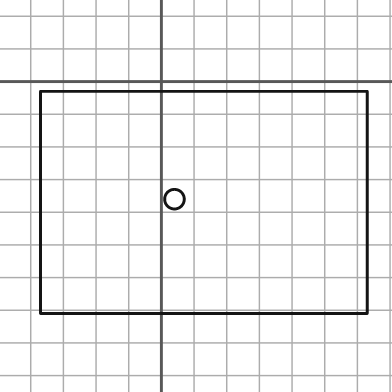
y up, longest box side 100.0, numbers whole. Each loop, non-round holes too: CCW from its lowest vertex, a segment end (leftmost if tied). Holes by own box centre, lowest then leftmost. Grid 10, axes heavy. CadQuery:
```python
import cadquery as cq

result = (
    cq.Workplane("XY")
    .moveTo(-37.0, -71.0)
    .lineTo(63.0, -71.0)
    .lineTo(63.0, -3.0)
    .lineTo(-37.0, -3.0)
    .close()
    .moveTo(4.0, -36.0)
    .circle(3.0)
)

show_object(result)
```